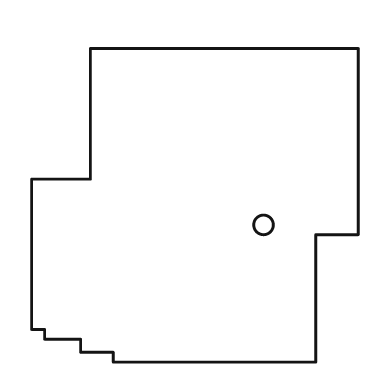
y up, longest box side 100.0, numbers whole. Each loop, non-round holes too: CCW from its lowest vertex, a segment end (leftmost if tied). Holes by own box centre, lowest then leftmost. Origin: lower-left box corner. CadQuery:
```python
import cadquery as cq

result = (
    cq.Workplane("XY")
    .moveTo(25.0, 0.0)
    .lineTo(87.0, 0.0)
    .lineTo(87.0, 39.0)
    .lineTo(100.0, 39.0)
    .lineTo(100.0, 96.0)
    .lineTo(18.0, 96.0)
    .lineTo(18.0, 56.0)
    .lineTo(0.0, 56.0)
    .lineTo(0.0, 10.0)
    .lineTo(4.0, 10.0)
    .lineTo(4.0, 7.0)
    .lineTo(15.0, 7.0)
    .lineTo(15.0, 3.0)
    .lineTo(25.0, 3.0)
    .close()
    .moveTo(71.0, 42.0)
    .circle(3.0)
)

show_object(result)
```